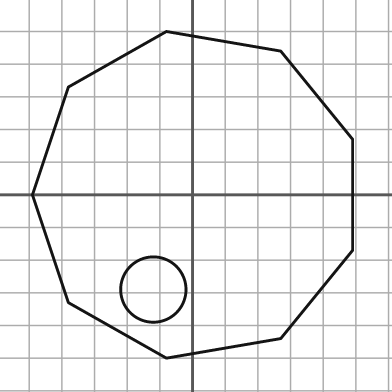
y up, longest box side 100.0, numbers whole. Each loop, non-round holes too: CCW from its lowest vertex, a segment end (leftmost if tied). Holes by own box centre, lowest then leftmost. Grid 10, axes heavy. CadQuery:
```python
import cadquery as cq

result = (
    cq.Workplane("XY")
    .moveTo(-8.0, -50.0)
    .lineTo(27.0, -44.0)
    .lineTo(49.0, -17.0)
    .lineTo(49.0, 17.0)
    .lineTo(27.0, 44.0)
    .lineTo(-8.0, 50.0)
    .lineTo(-38.0, 33.0)
    .lineTo(-49.0, 0.0)
    .lineTo(-38.0, -33.0)
    .close()
    .moveTo(-12.0, -29.0)
    .circle(10.0)
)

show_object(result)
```